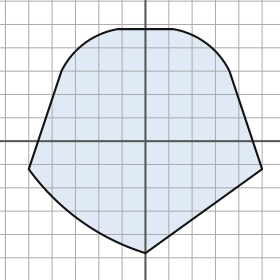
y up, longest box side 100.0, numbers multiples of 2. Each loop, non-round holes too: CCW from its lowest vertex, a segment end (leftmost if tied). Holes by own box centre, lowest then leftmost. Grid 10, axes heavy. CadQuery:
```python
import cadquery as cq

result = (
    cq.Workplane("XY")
    .moveTo(0.0, -48.0)
    .lineTo(50.0, -12.0)
    .lineTo(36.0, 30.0)
    .threePointArc((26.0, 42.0), (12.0, 48.0))
    .lineTo(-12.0, 48.0)
    .threePointArc((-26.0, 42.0), (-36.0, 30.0))
    .lineTo(-50.0, -12.0)
    .threePointArc((-28.0, -34.0), (0.0, -48.0))
    .close()
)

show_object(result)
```